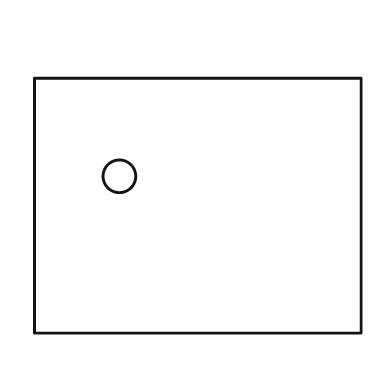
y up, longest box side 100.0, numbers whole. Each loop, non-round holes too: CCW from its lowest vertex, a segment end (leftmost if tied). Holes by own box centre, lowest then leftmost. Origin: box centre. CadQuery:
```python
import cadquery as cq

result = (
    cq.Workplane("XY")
    .moveTo(-50.0, -39.0)
    .lineTo(50.0, -39.0)
    .lineTo(50.0, 39.0)
    .lineTo(-50.0, 39.0)
    .close()
    .moveTo(-24.0, 9.0)
    .circle(5.0)
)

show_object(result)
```